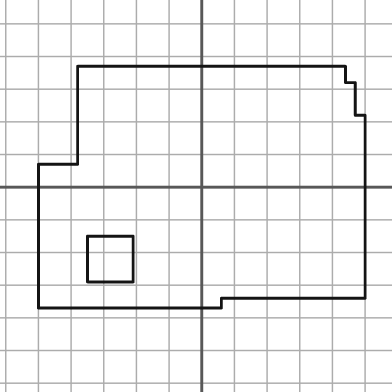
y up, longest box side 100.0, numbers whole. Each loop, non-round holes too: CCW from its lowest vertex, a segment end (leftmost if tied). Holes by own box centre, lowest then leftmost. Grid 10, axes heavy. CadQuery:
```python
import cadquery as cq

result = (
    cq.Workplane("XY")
    .moveTo(-50.0, -37.0)
    .lineTo(6.0, -37.0)
    .lineTo(6.0, -34.0)
    .lineTo(50.0, -34.0)
    .lineTo(50.0, 22.0)
    .lineTo(47.0, 22.0)
    .lineTo(47.0, 32.0)
    .lineTo(44.0, 32.0)
    .lineTo(44.0, 37.0)
    .lineTo(-38.0, 37.0)
    .lineTo(-38.0, 7.0)
    .lineTo(-50.0, 7.0)
    .close()
    .moveTo(-35.0, -29.0)
    .lineTo(-21.0, -29.0)
    .lineTo(-21.0, -15.0)
    .lineTo(-35.0, -15.0)
    .close()
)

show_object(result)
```